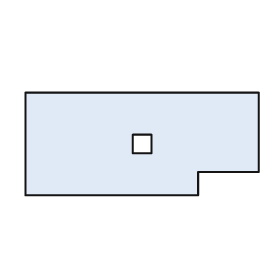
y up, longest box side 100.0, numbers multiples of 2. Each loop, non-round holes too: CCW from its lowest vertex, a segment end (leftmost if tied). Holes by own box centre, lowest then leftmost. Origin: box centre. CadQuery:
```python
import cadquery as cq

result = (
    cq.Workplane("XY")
    .moveTo(-50.0, -22.0)
    .lineTo(24.0, -22.0)
    .lineTo(24.0, -12.0)
    .lineTo(50.0, -12.0)
    .lineTo(50.0, 22.0)
    .lineTo(-50.0, 22.0)
    .close()
    .moveTo(-4.0, -4.0)
    .lineTo(4.0, -4.0)
    .lineTo(4.0, 4.0)
    .lineTo(-4.0, 4.0)
    .close()
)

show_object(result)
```